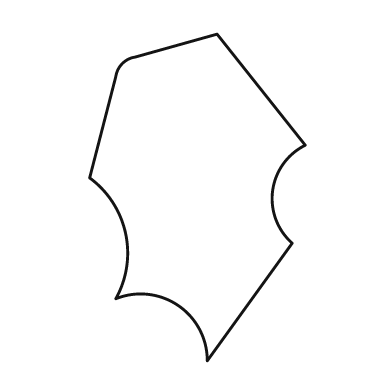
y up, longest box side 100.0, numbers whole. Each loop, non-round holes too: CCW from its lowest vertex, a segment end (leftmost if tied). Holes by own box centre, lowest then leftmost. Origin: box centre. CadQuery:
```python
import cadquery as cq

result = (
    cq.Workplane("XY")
    .moveTo(3.0, -50.0)
    .lineTo(29.0, -14.0)
    .threePointArc((23.0, 2.0), (33.0, 16.0))
    .lineTo(6.0, 50.0)
    .lineTo(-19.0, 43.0)
    .threePointArc((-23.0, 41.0), (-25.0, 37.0))
    .lineTo(-33.0, 6.0)
    .threePointArc((-22.0, -11.0), (-25.0, -31.0))
    .threePointArc((-6.0, -33.0), (3.0, -50.0))
    .close()
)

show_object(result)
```